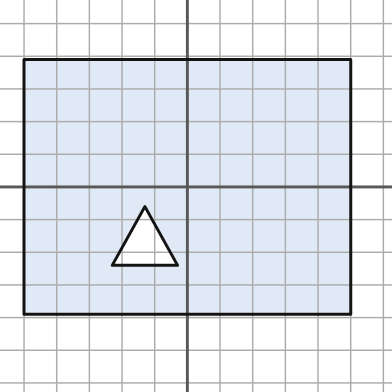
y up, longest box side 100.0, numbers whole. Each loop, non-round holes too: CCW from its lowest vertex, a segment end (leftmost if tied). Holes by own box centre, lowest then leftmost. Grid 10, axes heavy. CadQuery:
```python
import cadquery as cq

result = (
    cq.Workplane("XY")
    .moveTo(-50.0, -39.0)
    .lineTo(50.0, -39.0)
    .lineTo(50.0, 39.0)
    .lineTo(-50.0, 39.0)
    .close()
    .moveTo(-23.0, -24.0)
    .lineTo(-3.0, -24.0)
    .lineTo(-13.0, -6.0)
    .close()
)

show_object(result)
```